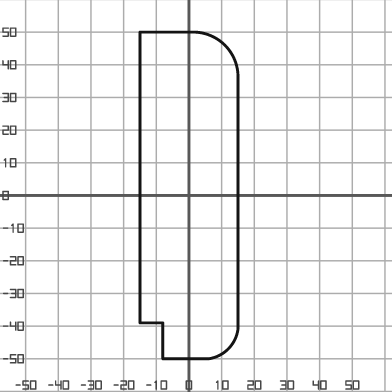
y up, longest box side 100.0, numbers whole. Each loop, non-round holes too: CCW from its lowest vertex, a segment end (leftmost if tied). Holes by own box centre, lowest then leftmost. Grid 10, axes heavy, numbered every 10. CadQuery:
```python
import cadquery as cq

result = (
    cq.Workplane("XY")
    .moveTo(-8.0, -50.0)
    .lineTo(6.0, -50.0)
    .threePointArc((12.0, -47.0), (15.0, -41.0))
    .lineTo(15.0, 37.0)
    .threePointArc((11.0, 46.0), (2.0, 50.0))
    .lineTo(-15.0, 50.0)
    .lineTo(-15.0, -39.0)
    .lineTo(-8.0, -39.0)
    .close()
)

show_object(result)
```